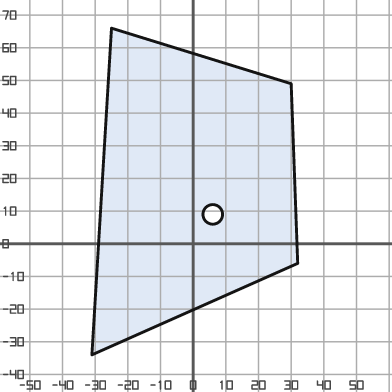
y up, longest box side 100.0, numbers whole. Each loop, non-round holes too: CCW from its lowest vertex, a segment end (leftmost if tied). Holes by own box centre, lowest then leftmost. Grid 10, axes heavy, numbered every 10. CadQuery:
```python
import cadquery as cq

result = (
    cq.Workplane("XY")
    .moveTo(-31.0, -34.0)
    .lineTo(32.0, -6.0)
    .lineTo(30.0, 49.0)
    .lineTo(-25.0, 66.0)
    .close()
    .moveTo(6.0, 9.0)
    .circle(3.0)
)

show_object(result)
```